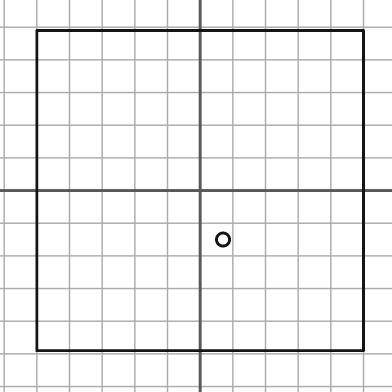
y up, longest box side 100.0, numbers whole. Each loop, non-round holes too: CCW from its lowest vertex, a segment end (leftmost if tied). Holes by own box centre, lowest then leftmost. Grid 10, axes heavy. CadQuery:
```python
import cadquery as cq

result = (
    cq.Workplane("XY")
    .moveTo(-50.0, -49.0)
    .lineTo(50.0, -49.0)
    .lineTo(50.0, 49.0)
    .lineTo(-50.0, 49.0)
    .close()
    .moveTo(7.0, -15.0)
    .circle(2.0)
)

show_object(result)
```